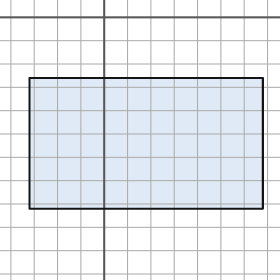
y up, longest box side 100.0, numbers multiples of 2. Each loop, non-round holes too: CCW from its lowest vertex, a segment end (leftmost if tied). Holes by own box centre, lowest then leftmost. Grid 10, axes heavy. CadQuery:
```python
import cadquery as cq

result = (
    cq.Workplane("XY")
    .moveTo(-32.0, -82.0)
    .lineTo(68.0, -82.0)
    .lineTo(68.0, -26.0)
    .lineTo(-32.0, -26.0)
    .close()
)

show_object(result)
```